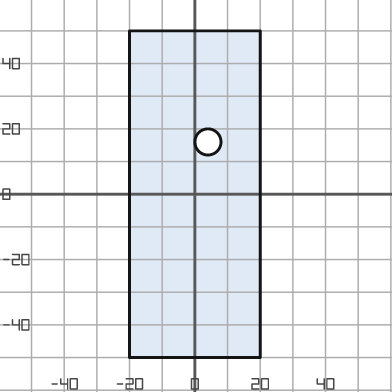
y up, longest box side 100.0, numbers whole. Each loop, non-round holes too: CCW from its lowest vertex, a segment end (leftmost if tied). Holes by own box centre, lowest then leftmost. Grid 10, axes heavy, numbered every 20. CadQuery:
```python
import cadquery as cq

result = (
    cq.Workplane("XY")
    .moveTo(-20.0, -50.0)
    .lineTo(20.0, -50.0)
    .lineTo(20.0, 50.0)
    .lineTo(-20.0, 50.0)
    .close()
    .moveTo(4.0, 16.0)
    .circle(4.0)
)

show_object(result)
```